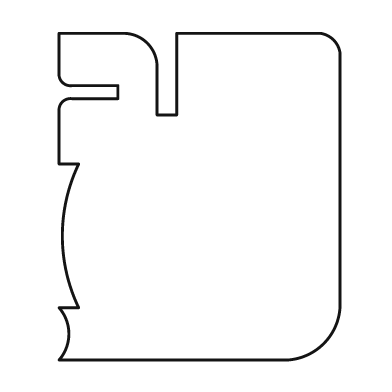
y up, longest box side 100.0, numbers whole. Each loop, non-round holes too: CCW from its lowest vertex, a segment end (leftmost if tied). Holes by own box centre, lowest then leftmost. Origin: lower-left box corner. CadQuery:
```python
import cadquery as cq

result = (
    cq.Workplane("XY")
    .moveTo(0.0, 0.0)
    .lineTo(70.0, 0.0)
    .threePointArc((81.0, 5.0), (86.0, 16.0))
    .lineTo(86.0, 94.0)
    .threePointArc((84.0, 98.0), (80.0, 100.0))
    .lineTo(36.0, 100.0)
    .lineTo(36.0, 75.0)
    .lineTo(30.0, 75.0)
    .lineTo(30.0, 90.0)
    .threePointArc((27.0, 97.0), (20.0, 100.0))
    .lineTo(0.0, 100.0)
    .lineTo(0.0, 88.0)
    .threePointArc((1.0, 85.0), (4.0, 84.0))
    .lineTo(18.0, 84.0)
    .lineTo(18.0, 80.0)
    .lineTo(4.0, 80.0)
    .threePointArc((1.0, 79.0), (0.0, 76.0))
    .lineTo(0.0, 60.0)
    .lineTo(6.0, 60.0)
    .threePointArc((1.0, 38.0), (6.0, 16.0))
    .lineTo(0.0, 16.0)
    .threePointArc((3.0, 8.0), (0.0, 0.0))
    .close()
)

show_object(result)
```